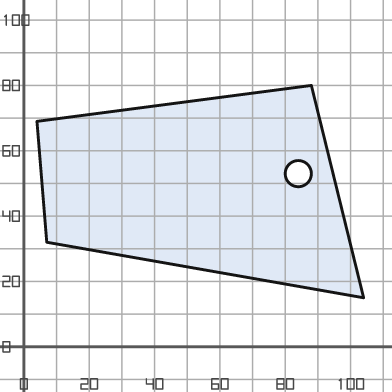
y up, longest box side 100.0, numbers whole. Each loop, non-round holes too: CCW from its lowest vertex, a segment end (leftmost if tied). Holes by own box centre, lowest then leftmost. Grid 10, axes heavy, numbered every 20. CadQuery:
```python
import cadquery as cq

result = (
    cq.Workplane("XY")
    .moveTo(104.0, 15.0)
    .lineTo(88.0, 80.0)
    .lineTo(4.0, 69.0)
    .lineTo(7.0, 32.0)
    .close()
    .moveTo(84.0, 53.0)
    .circle(4.0)
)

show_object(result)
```